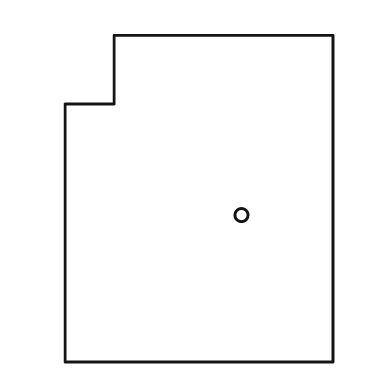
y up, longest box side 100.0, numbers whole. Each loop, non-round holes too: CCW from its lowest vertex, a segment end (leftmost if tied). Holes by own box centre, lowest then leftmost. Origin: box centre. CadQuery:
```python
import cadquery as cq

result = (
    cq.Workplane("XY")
    .moveTo(-41.0, -50.0)
    .lineTo(41.0, -50.0)
    .lineTo(41.0, 50.0)
    .lineTo(-26.0, 50.0)
    .lineTo(-26.0, 29.0)
    .lineTo(-41.0, 29.0)
    .close()
    .moveTo(13.0, -5.0)
    .circle(2.0)
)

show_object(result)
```